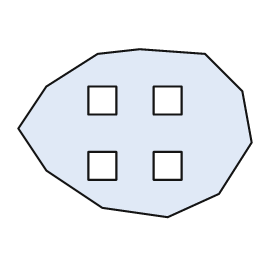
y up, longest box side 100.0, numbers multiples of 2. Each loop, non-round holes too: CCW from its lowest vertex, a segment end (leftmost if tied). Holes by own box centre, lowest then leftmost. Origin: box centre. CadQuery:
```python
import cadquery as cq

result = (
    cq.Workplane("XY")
    .moveTo(14.0, -36.0)
    .lineTo(36.0, -26.0)
    .lineTo(50.0, -4.0)
    .lineTo(46.0, 18.0)
    .lineTo(30.0, 34.0)
    .lineTo(2.0, 36.0)
    .lineTo(-16.0, 34.0)
    .lineTo(-38.0, 20.0)
    .lineTo(-50.0, 2.0)
    .lineTo(-38.0, -16.0)
    .lineTo(-14.0, -32.0)
    .close()
    .moveTo(-20.0, -20.0)
    .lineTo(-8.0, -20.0)
    .lineTo(-8.0, -8.0)
    .lineTo(-20.0, -8.0)
    .close()
    .moveTo(8.0, -20.0)
    .lineTo(20.0, -20.0)
    .lineTo(20.0, -8.0)
    .lineTo(8.0, -8.0)
    .close()
    .moveTo(-20.0, 8.0)
    .lineTo(-8.0, 8.0)
    .lineTo(-8.0, 20.0)
    .lineTo(-20.0, 20.0)
    .close()
    .moveTo(8.0, 8.0)
    .lineTo(20.0, 8.0)
    .lineTo(20.0, 20.0)
    .lineTo(8.0, 20.0)
    .close()
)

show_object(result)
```